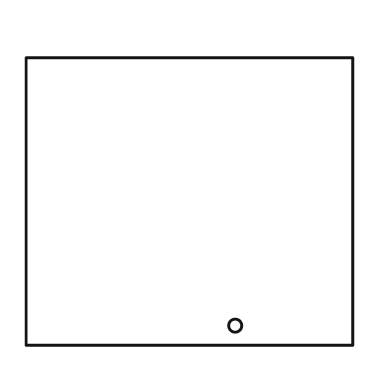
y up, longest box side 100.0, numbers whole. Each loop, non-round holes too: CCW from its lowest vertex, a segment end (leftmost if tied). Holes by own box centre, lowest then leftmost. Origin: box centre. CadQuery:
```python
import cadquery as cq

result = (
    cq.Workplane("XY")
    .moveTo(-50.0, -44.0)
    .lineTo(50.0, -44.0)
    .lineTo(50.0, 44.0)
    .lineTo(-50.0, 44.0)
    .close()
    .moveTo(14.0, -38.0)
    .circle(2.0)
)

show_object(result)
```